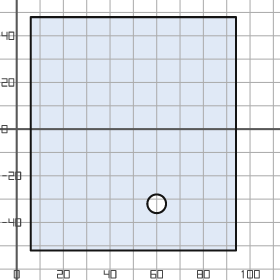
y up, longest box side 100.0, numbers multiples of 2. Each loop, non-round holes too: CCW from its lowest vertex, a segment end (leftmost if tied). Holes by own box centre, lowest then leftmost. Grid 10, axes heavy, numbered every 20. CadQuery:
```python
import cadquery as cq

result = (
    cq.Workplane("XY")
    .moveTo(6.0, -52.0)
    .lineTo(94.0, -52.0)
    .lineTo(94.0, 48.0)
    .lineTo(6.0, 48.0)
    .close()
    .moveTo(60.0, -32.0)
    .circle(4.0)
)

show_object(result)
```